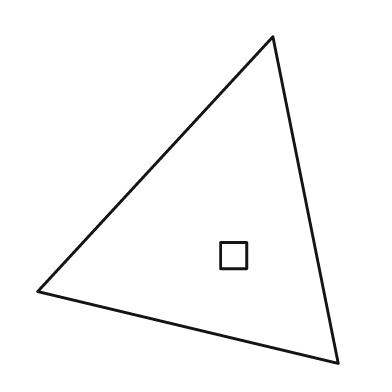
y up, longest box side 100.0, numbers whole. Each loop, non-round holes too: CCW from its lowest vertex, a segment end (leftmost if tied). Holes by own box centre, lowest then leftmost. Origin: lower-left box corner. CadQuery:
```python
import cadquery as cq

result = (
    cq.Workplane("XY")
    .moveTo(92.0, 0.0)
    .lineTo(72.0, 100.0)
    .lineTo(0.0, 22.0)
    .close()
    .moveTo(56.0, 29.0)
    .lineTo(64.0, 29.0)
    .lineTo(64.0, 37.0)
    .lineTo(56.0, 37.0)
    .close()
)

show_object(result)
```